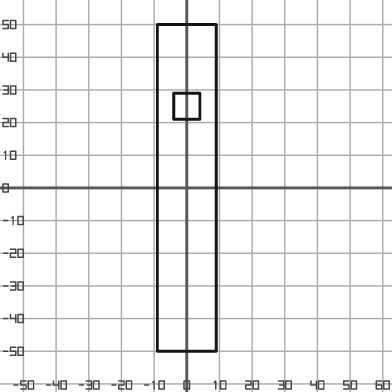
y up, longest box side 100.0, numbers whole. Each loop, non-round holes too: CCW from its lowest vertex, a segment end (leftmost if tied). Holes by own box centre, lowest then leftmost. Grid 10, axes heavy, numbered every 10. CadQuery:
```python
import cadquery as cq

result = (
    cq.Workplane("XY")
    .moveTo(-9.0, -50.0)
    .lineTo(9.0, -50.0)
    .lineTo(9.0, 50.0)
    .lineTo(-9.0, 50.0)
    .close()
    .moveTo(-4.0, 21.0)
    .lineTo(4.0, 21.0)
    .lineTo(4.0, 29.0)
    .lineTo(-4.0, 29.0)
    .close()
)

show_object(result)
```